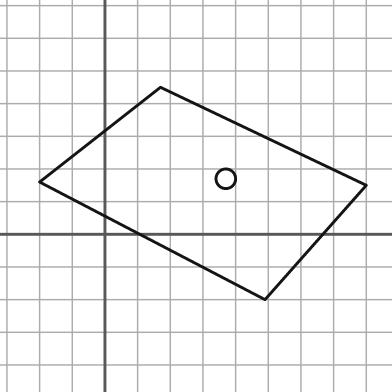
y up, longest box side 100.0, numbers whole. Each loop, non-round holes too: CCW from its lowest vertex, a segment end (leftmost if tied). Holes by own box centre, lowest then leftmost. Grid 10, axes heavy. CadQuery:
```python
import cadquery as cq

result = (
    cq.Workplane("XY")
    .moveTo(49.0, -20.0)
    .lineTo(80.0, 15.0)
    .lineTo(17.0, 45.0)
    .lineTo(-20.0, 16.0)
    .close()
    .moveTo(37.0, 17.0)
    .circle(3.0)
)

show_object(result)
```